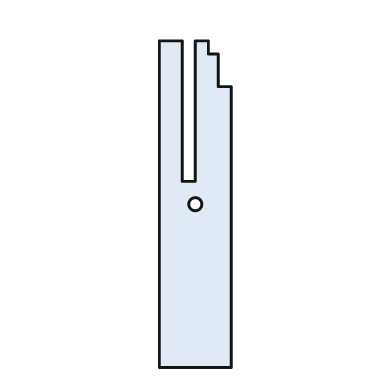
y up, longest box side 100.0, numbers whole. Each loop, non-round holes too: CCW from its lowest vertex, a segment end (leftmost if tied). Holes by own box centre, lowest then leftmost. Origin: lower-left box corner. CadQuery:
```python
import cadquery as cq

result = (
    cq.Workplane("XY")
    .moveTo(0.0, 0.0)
    .lineTo(22.0, 0.0)
    .lineTo(22.0, 86.0)
    .lineTo(18.0, 86.0)
    .lineTo(18.0, 96.0)
    .lineTo(15.0, 96.0)
    .lineTo(15.0, 100.0)
    .lineTo(11.0, 100.0)
    .lineTo(11.0, 57.0)
    .lineTo(7.0, 57.0)
    .lineTo(7.0, 100.0)
    .lineTo(0.0, 100.0)
    .close()
    .moveTo(11.0, 50.0)
    .circle(2.0)
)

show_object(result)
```